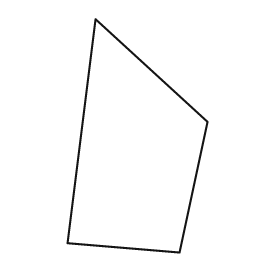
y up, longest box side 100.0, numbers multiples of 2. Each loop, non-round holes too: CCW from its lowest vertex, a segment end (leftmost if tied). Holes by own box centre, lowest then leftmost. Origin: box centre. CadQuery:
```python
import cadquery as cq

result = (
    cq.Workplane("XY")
    .moveTo(18.0, -50.0)
    .lineTo(30.0, 6.0)
    .lineTo(-18.0, 50.0)
    .lineTo(-30.0, -46.0)
    .close()
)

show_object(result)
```